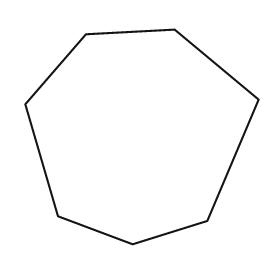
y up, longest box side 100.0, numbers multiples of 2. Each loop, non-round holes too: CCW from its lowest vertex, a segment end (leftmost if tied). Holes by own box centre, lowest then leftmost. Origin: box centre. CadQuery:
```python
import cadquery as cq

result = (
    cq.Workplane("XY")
    .moveTo(-4.0, -46.0)
    .lineTo(28.0, -36.0)
    .lineTo(50.0, 16.0)
    .lineTo(14.0, 46.0)
    .lineTo(-24.0, 44.0)
    .lineTo(-50.0, 14.0)
    .lineTo(-36.0, -34.0)
    .close()
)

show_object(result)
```